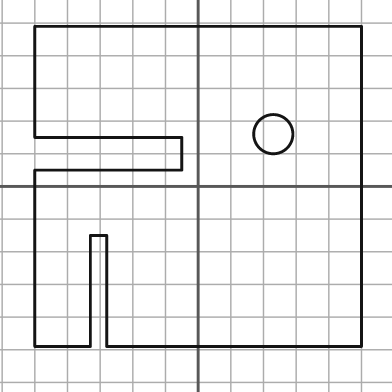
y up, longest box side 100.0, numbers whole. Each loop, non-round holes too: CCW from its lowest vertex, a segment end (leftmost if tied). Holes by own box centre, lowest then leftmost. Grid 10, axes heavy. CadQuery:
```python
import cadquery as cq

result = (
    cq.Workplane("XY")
    .moveTo(-50.0, -49.0)
    .lineTo(-33.0, -49.0)
    .lineTo(-33.0, -15.0)
    .lineTo(-28.0, -15.0)
    .lineTo(-28.0, -49.0)
    .lineTo(50.0, -49.0)
    .lineTo(50.0, 49.0)
    .lineTo(-50.0, 49.0)
    .lineTo(-50.0, 15.0)
    .lineTo(-5.0, 15.0)
    .lineTo(-5.0, 5.0)
    .lineTo(-50.0, 5.0)
    .close()
    .moveTo(23.0, 16.0)
    .circle(6.0)
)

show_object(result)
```